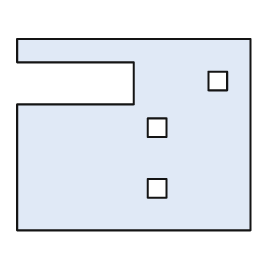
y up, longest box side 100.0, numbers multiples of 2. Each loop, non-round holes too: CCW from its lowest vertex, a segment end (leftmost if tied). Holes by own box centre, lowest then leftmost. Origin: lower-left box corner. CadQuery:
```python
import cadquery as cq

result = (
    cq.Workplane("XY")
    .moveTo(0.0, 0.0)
    .lineTo(100.0, 0.0)
    .lineTo(100.0, 82.0)
    .lineTo(0.0, 82.0)
    .lineTo(0.0, 72.0)
    .lineTo(50.0, 72.0)
    .lineTo(50.0, 54.0)
    .lineTo(0.0, 54.0)
    .close()
    .moveTo(56.0, 14.0)
    .lineTo(64.0, 14.0)
    .lineTo(64.0, 22.0)
    .lineTo(56.0, 22.0)
    .close()
    .moveTo(56.0, 40.0)
    .lineTo(64.0, 40.0)
    .lineTo(64.0, 48.0)
    .lineTo(56.0, 48.0)
    .close()
    .moveTo(82.0, 60.0)
    .lineTo(90.0, 60.0)
    .lineTo(90.0, 68.0)
    .lineTo(82.0, 68.0)
    .close()
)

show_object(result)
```